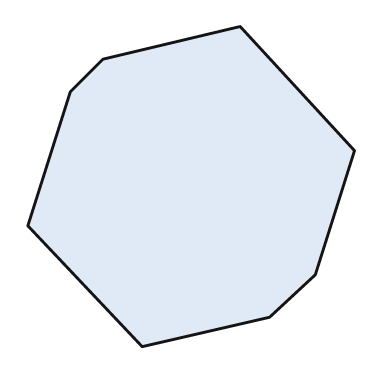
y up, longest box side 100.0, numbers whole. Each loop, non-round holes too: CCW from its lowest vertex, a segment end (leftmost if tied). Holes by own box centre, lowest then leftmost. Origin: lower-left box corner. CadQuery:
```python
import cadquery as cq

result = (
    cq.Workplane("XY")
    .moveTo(35.0, 0.0)
    .lineTo(74.0, 9.0)
    .lineTo(88.0, 22.0)
    .lineTo(100.0, 60.0)
    .lineTo(65.0, 98.0)
    .lineTo(23.0, 88.0)
    .lineTo(13.0, 78.0)
    .lineTo(0.0, 37.0)
    .close()
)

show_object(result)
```